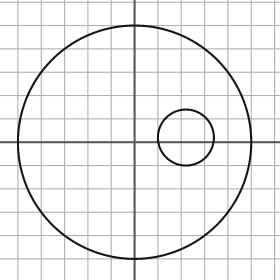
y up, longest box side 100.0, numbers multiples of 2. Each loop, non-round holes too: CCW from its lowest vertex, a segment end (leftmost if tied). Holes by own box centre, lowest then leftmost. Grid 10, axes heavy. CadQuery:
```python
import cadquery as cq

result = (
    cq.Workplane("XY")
    .moveTo(0.0, 0.0)
    .circle(50.0)
    .moveTo(22.0, 2.0)
    .circle(12.0)
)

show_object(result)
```